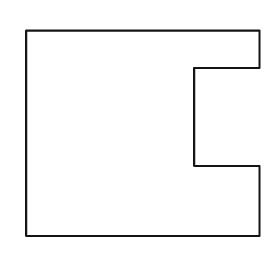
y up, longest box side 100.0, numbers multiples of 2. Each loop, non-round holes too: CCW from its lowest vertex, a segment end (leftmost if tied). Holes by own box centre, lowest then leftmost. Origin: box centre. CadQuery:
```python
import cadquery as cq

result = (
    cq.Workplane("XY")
    .moveTo(-50.0, -44.0)
    .lineTo(50.0, -44.0)
    .lineTo(50.0, -14.0)
    .lineTo(22.0, -14.0)
    .lineTo(22.0, 28.0)
    .lineTo(50.0, 28.0)
    .lineTo(50.0, 44.0)
    .lineTo(-50.0, 44.0)
    .close()
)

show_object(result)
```